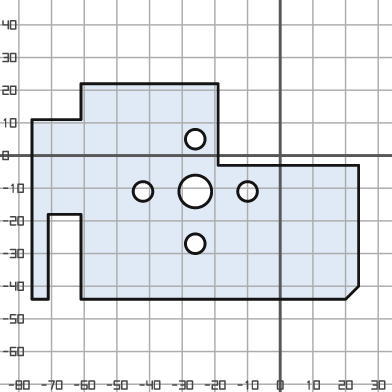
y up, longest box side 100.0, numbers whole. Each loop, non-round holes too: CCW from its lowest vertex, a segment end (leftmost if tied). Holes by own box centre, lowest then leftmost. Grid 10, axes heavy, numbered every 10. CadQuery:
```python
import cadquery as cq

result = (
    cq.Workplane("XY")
    .moveTo(-76.0, -44.0)
    .lineTo(-71.0, -44.0)
    .lineTo(-71.0, -18.0)
    .lineTo(-61.0, -18.0)
    .lineTo(-61.0, -44.0)
    .lineTo(20.0, -44.0)
    .lineTo(24.0, -40.0)
    .lineTo(24.0, -3.0)
    .lineTo(-19.0, -3.0)
    .lineTo(-19.0, 22.0)
    .lineTo(-61.0, 22.0)
    .lineTo(-61.0, 11.0)
    .lineTo(-76.0, 11.0)
    .close()
    .moveTo(-26.0, -27.0)
    .circle(3.0)
    .moveTo(-42.0, -11.0)
    .circle(3.0)
    .moveTo(-26.0, -11.0)
    .circle(5.0)
    .moveTo(-10.0, -11.0)
    .circle(3.0)
    .moveTo(-26.0, 5.0)
    .circle(3.0)
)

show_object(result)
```